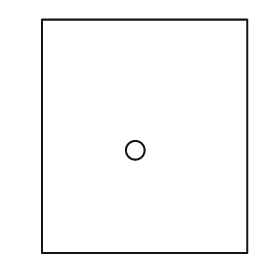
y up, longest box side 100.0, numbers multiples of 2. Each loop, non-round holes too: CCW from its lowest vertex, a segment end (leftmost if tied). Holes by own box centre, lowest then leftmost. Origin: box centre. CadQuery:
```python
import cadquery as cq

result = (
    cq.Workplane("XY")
    .moveTo(-44.0, -50.0)
    .lineTo(44.0, -50.0)
    .lineTo(44.0, 50.0)
    .lineTo(-44.0, 50.0)
    .close()
    .moveTo(-4.0, -6.0)
    .circle(4.0)
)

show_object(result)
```